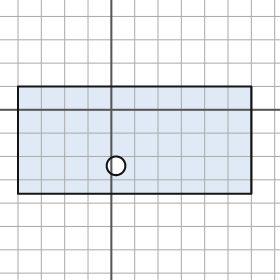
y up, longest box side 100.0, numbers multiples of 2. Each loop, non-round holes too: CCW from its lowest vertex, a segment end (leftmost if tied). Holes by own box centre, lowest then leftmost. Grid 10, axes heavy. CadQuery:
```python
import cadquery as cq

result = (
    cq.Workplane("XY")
    .moveTo(-40.0, -36.0)
    .lineTo(60.0, -36.0)
    .lineTo(60.0, 10.0)
    .lineTo(-40.0, 10.0)
    .close()
    .moveTo(2.0, -24.0)
    .circle(4.0)
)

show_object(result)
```